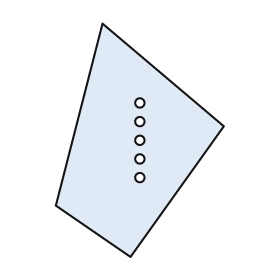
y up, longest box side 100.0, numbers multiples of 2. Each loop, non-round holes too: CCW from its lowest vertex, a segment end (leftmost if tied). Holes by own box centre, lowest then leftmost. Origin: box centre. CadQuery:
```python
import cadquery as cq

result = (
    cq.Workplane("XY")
    .moveTo(-4.0, -50.0)
    .lineTo(36.0, 6.0)
    .lineTo(-16.0, 50.0)
    .lineTo(-36.0, -28.0)
    .close()
    .moveTo(0.0, -16.0)
    .circle(2.0)
    .moveTo(0.0, -8.0)
    .circle(2.0)
    .moveTo(0.0, 0.0)
    .circle(2.0)
    .moveTo(0.0, 8.0)
    .circle(2.0)
    .moveTo(0.0, 16.0)
    .circle(2.0)
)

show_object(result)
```